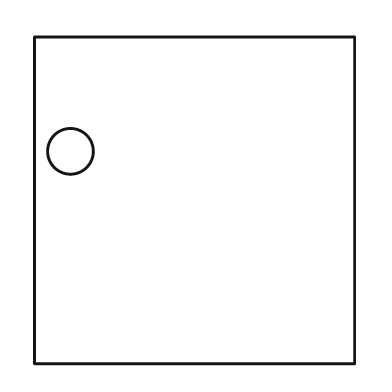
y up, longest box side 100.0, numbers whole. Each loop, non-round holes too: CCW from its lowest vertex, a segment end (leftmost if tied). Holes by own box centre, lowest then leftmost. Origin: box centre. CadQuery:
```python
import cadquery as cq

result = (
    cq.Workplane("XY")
    .moveTo(-49.0, -50.0)
    .lineTo(49.0, -50.0)
    .lineTo(49.0, 50.0)
    .lineTo(-49.0, 50.0)
    .close()
    .moveTo(-38.0, 15.0)
    .circle(7.0)
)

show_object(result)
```